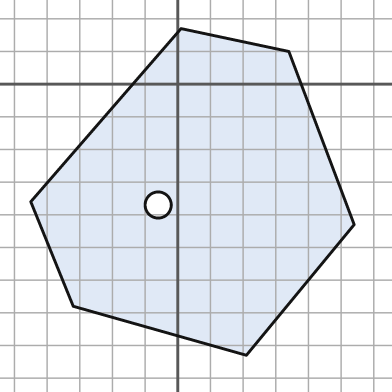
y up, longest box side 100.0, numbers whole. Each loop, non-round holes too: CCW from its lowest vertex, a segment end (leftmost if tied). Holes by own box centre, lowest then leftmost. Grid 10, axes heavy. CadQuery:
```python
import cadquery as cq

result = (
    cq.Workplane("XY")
    .moveTo(21.0, -83.0)
    .lineTo(54.0, -43.0)
    .lineTo(34.0, 10.0)
    .lineTo(1.0, 17.0)
    .lineTo(-45.0, -36.0)
    .lineTo(-32.0, -68.0)
    .close()
    .moveTo(-6.0, -37.0)
    .circle(4.0)
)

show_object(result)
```